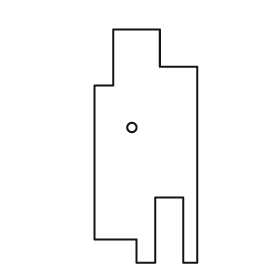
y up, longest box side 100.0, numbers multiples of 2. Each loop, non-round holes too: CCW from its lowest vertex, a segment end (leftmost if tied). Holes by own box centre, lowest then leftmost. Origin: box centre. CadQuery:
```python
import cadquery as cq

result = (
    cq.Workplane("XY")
    .moveTo(-4.0, -50.0)
    .lineTo(4.0, -50.0)
    .lineTo(4.0, -22.0)
    .lineTo(16.0, -22.0)
    .lineTo(16.0, -50.0)
    .lineTo(22.0, -50.0)
    .lineTo(22.0, 34.0)
    .lineTo(6.0, 34.0)
    .lineTo(6.0, 50.0)
    .lineTo(-14.0, 50.0)
    .lineTo(-14.0, 26.0)
    .lineTo(-22.0, 26.0)
    .lineTo(-22.0, -40.0)
    .lineTo(-4.0, -40.0)
    .close()
    .moveTo(-6.0, 8.0)
    .circle(2.0)
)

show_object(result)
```